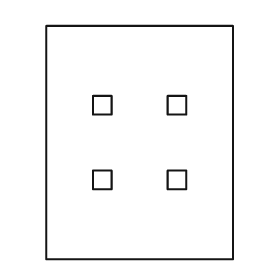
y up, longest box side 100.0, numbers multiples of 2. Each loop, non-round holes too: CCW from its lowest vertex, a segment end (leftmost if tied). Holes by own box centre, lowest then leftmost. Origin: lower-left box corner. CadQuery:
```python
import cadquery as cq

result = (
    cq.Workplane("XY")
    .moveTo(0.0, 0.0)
    .lineTo(80.0, 0.0)
    .lineTo(80.0, 100.0)
    .lineTo(0.0, 100.0)
    .close()
    .moveTo(20.0, 30.0)
    .lineTo(28.0, 30.0)
    .lineTo(28.0, 38.0)
    .lineTo(20.0, 38.0)
    .close()
    .moveTo(52.0, 30.0)
    .lineTo(60.0, 30.0)
    .lineTo(60.0, 38.0)
    .lineTo(52.0, 38.0)
    .close()
    .moveTo(20.0, 62.0)
    .lineTo(28.0, 62.0)
    .lineTo(28.0, 70.0)
    .lineTo(20.0, 70.0)
    .close()
    .moveTo(52.0, 62.0)
    .lineTo(60.0, 62.0)
    .lineTo(60.0, 70.0)
    .lineTo(52.0, 70.0)
    .close()
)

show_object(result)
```